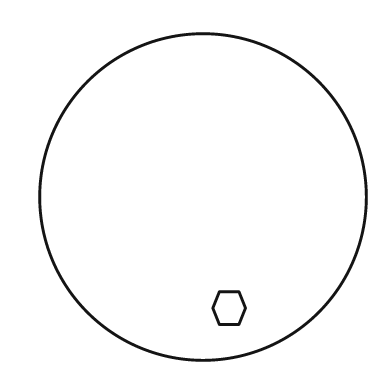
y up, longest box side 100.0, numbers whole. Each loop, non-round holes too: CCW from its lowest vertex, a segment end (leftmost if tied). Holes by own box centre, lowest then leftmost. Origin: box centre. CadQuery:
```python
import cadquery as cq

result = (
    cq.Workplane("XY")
    .moveTo(0.0, 0.0)
    .circle(50.0)
    .moveTo(5.0, -39.0)
    .lineTo(11.0, -39.0)
    .lineTo(13.0, -34.0)
    .lineTo(11.0, -29.0)
    .lineTo(5.0, -29.0)
    .lineTo(3.0, -34.0)
    .close()
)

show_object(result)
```